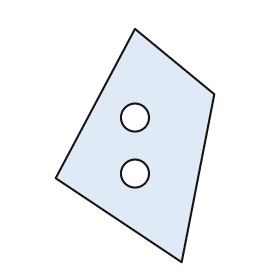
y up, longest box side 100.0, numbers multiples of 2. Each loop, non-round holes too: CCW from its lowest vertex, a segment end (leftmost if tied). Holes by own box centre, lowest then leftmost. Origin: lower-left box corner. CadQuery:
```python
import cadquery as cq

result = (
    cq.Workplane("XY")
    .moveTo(54.0, 0.0)
    .lineTo(68.0, 72.0)
    .lineTo(34.0, 100.0)
    .lineTo(0.0, 36.0)
    .close()
    .moveTo(34.0, 38.0)
    .circle(6.0)
    .moveTo(34.0, 62.0)
    .circle(6.0)
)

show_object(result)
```